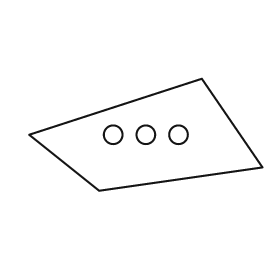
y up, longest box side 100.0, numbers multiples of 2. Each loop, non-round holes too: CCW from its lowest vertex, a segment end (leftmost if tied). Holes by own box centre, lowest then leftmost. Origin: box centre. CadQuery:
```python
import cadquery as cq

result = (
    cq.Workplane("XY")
    .moveTo(-20.0, -24.0)
    .lineTo(50.0, -14.0)
    .lineTo(24.0, 24.0)
    .lineTo(-50.0, 0.0)
    .close()
    .moveTo(-14.0, 0.0)
    .circle(4.0)
    .moveTo(0.0, 0.0)
    .circle(4.0)
    .moveTo(14.0, 0.0)
    .circle(4.0)
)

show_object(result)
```